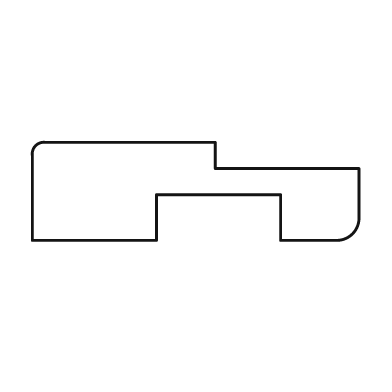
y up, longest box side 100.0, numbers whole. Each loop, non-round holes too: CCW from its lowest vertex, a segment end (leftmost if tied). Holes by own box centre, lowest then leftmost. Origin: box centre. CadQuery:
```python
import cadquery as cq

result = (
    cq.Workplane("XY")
    .moveTo(-50.0, -15.0)
    .lineTo(-12.0, -15.0)
    .lineTo(-12.0, -1.0)
    .lineTo(26.0, -1.0)
    .lineTo(26.0, -15.0)
    .lineTo(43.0, -15.0)
    .threePointArc((48.0, -13.0), (50.0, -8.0))
    .lineTo(50.0, 7.0)
    .lineTo(6.0, 7.0)
    .lineTo(6.0, 15.0)
    .lineTo(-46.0, 15.0)
    .threePointArc((-49.0, 14.0), (-50.0, 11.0))
    .close()
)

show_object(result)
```